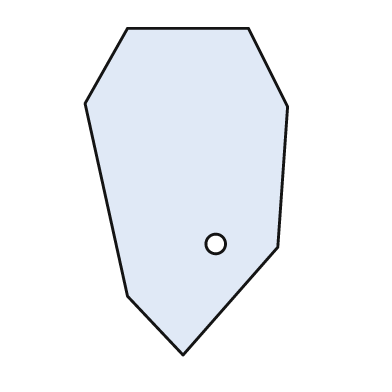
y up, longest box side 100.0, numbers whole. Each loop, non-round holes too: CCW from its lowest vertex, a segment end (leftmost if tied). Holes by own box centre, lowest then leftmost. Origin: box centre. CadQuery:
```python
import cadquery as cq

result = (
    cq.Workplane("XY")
    .moveTo(-1.0, -50.0)
    .lineTo(28.0, -17.0)
    .lineTo(31.0, 26.0)
    .lineTo(19.0, 50.0)
    .lineTo(-18.0, 50.0)
    .lineTo(-31.0, 27.0)
    .lineTo(-18.0, -32.0)
    .close()
    .moveTo(9.0, -16.0)
    .circle(3.0)
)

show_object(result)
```